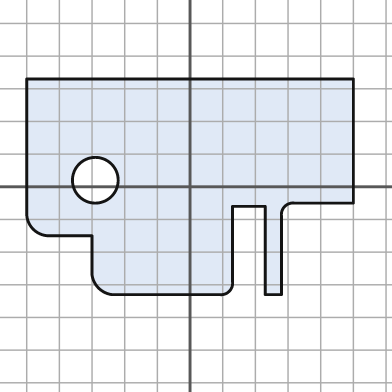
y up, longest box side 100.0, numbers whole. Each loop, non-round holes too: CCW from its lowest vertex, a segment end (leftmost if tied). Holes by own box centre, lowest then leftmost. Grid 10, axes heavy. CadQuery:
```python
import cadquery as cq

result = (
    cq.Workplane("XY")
    .moveTo(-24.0, -33.0)
    .lineTo(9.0, -33.0)
    .threePointArc((12.0, -32.0), (13.0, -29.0))
    .lineTo(13.0, -6.0)
    .lineTo(23.0, -6.0)
    .lineTo(23.0, -33.0)
    .lineTo(28.0, -33.0)
    .lineTo(28.0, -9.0)
    .threePointArc((29.0, -6.0), (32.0, -5.0))
    .lineTo(50.0, -5.0)
    .lineTo(50.0, 33.0)
    .lineTo(-50.0, 33.0)
    .lineTo(-50.0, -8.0)
    .threePointArc((-48.0, -13.0), (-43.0, -15.0))
    .lineTo(-30.0, -15.0)
    .lineTo(-30.0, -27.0)
    .threePointArc((-28.0, -31.0), (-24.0, -33.0))
    .close()
    .moveTo(-29.0, 2.0)
    .circle(7.0)
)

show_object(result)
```